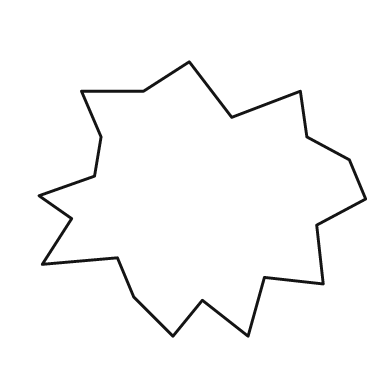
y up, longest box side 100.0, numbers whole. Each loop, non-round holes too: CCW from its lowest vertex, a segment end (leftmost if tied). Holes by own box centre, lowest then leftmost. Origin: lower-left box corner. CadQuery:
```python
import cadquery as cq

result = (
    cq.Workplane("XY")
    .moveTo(41.0, 0.0)
    .lineTo(50.0, 11.0)
    .lineTo(64.0, 0.0)
    .lineTo(69.0, 18.0)
    .lineTo(87.0, 16.0)
    .lineTo(85.0, 34.0)
    .lineTo(100.0, 42.0)
    .lineTo(95.0, 54.0)
    .lineTo(82.0, 61.0)
    .lineTo(80.0, 75.0)
    .lineTo(59.0, 67.0)
    .lineTo(46.0, 84.0)
    .lineTo(32.0, 75.0)
    .lineTo(13.0, 75.0)
    .lineTo(19.0, 61.0)
    .lineTo(17.0, 49.0)
    .lineTo(0.0, 43.0)
    .lineTo(10.0, 36.0)
    .lineTo(1.0, 22.0)
    .lineTo(24.0, 24.0)
    .lineTo(29.0, 12.0)
    .close()
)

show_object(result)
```